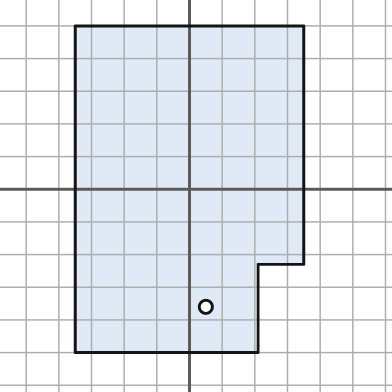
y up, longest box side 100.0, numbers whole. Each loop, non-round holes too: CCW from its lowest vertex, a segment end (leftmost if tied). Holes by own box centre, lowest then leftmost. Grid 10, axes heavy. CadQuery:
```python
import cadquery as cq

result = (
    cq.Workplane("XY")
    .moveTo(-35.0, -50.0)
    .lineTo(21.0, -50.0)
    .lineTo(21.0, -23.0)
    .lineTo(35.0, -23.0)
    .lineTo(35.0, 50.0)
    .lineTo(-35.0, 50.0)
    .close()
    .moveTo(5.0, -36.0)
    .circle(2.0)
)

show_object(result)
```